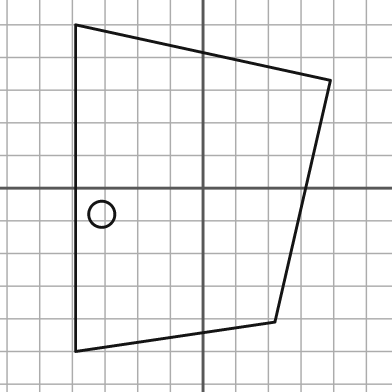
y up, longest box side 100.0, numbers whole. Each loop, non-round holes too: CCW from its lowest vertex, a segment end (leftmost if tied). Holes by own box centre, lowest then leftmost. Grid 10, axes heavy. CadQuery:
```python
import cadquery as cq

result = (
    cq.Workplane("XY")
    .moveTo(-39.0, -50.0)
    .lineTo(22.0, -41.0)
    .lineTo(39.0, 33.0)
    .lineTo(-39.0, 50.0)
    .close()
    .moveTo(-31.0, -8.0)
    .circle(4.0)
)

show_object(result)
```